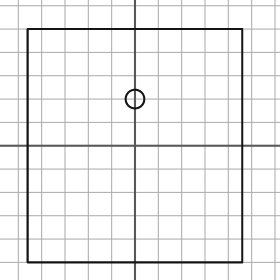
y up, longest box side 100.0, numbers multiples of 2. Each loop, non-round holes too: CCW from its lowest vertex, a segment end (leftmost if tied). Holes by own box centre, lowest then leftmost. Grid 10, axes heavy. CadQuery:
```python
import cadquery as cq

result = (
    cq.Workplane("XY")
    .moveTo(-46.0, -50.0)
    .lineTo(46.0, -50.0)
    .lineTo(46.0, 50.0)
    .lineTo(-46.0, 50.0)
    .close()
    .moveTo(0.0, 20.0)
    .circle(4.0)
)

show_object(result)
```